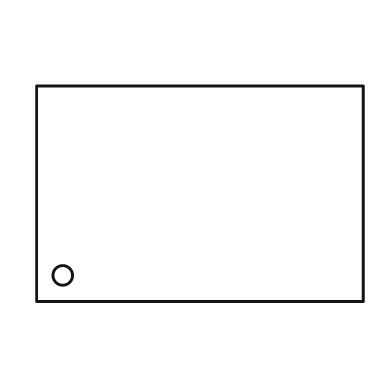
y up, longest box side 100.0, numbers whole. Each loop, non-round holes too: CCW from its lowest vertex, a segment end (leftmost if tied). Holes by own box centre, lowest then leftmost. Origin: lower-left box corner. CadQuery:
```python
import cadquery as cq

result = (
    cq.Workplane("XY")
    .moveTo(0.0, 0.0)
    .lineTo(100.0, 0.0)
    .lineTo(100.0, 66.0)
    .lineTo(0.0, 66.0)
    .close()
    .moveTo(8.0, 8.0)
    .circle(3.0)
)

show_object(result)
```